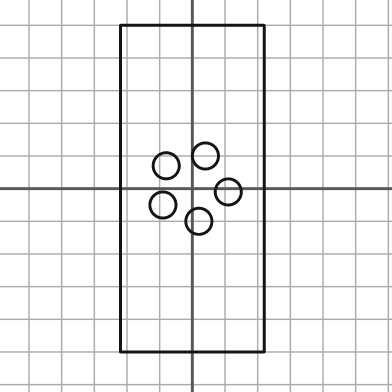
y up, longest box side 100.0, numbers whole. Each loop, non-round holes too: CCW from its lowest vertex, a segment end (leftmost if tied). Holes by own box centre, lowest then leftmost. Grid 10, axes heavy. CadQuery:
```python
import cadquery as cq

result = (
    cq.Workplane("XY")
    .moveTo(-22.0, -50.0)
    .lineTo(22.0, -50.0)
    .lineTo(22.0, 50.0)
    .lineTo(-22.0, 50.0)
    .close()
    .moveTo(2.0, -10.0)
    .circle(4.0)
    .moveTo(-9.0, -5.0)
    .circle(4.0)
    .moveTo(11.0, -1.0)
    .circle(4.0)
    .moveTo(-8.0, 7.0)
    .circle(4.0)
    .moveTo(4.0, 10.0)
    .circle(4.0)
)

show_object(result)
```